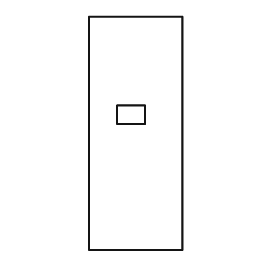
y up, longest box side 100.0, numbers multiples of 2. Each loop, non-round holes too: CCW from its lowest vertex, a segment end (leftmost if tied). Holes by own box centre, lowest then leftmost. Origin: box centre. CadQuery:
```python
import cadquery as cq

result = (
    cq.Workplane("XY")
    .moveTo(-20.0, -50.0)
    .lineTo(20.0, -50.0)
    .lineTo(20.0, 50.0)
    .lineTo(-20.0, 50.0)
    .close()
    .moveTo(-8.0, 4.0)
    .lineTo(4.0, 4.0)
    .lineTo(4.0, 12.0)
    .lineTo(-8.0, 12.0)
    .close()
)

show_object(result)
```